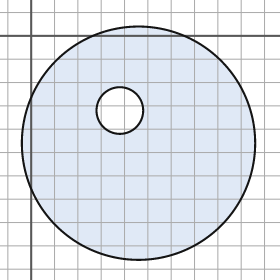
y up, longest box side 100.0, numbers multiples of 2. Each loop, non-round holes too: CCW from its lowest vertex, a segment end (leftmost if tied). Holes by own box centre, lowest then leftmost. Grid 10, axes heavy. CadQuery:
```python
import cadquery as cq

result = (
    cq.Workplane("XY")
    .moveTo(46.0, -46.0)
    .circle(50.0)
    .moveTo(38.0, -32.0)
    .circle(10.0)
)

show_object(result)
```